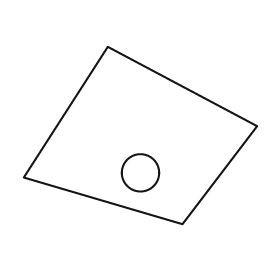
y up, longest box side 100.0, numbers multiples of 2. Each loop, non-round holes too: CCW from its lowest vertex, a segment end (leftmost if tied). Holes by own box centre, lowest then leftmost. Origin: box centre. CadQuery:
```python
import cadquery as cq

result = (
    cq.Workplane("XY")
    .moveTo(18.0, -38.0)
    .lineTo(50.0, 4.0)
    .lineTo(-14.0, 38.0)
    .lineTo(-50.0, -18.0)
    .close()
    .moveTo(0.0, -16.0)
    .circle(8.0)
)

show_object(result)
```